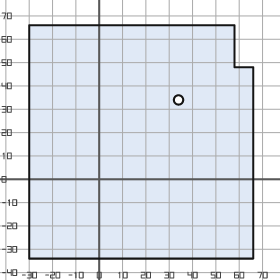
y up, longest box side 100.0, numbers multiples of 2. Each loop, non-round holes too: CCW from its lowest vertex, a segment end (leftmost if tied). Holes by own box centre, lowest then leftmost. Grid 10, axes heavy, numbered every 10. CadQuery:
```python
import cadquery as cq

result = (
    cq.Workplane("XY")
    .moveTo(-30.0, -34.0)
    .lineTo(66.0, -34.0)
    .lineTo(66.0, 48.0)
    .lineTo(58.0, 48.0)
    .lineTo(58.0, 66.0)
    .lineTo(-30.0, 66.0)
    .close()
    .moveTo(34.0, 34.0)
    .circle(2.0)
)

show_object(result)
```